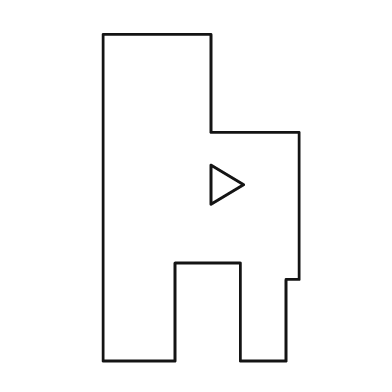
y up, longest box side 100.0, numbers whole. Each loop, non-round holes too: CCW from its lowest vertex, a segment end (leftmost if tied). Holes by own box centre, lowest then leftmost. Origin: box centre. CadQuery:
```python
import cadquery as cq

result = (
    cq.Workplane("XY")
    .moveTo(-30.0, -50.0)
    .lineTo(-8.0, -50.0)
    .lineTo(-8.0, -20.0)
    .lineTo(12.0, -20.0)
    .lineTo(12.0, -50.0)
    .lineTo(26.0, -50.0)
    .lineTo(26.0, -25.0)
    .lineTo(30.0, -25.0)
    .lineTo(30.0, 20.0)
    .lineTo(3.0, 20.0)
    .lineTo(3.0, 50.0)
    .lineTo(-30.0, 50.0)
    .close()
    .moveTo(3.0, -2.0)
    .lineTo(13.0, 4.0)
    .lineTo(3.0, 10.0)
    .close()
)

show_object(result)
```